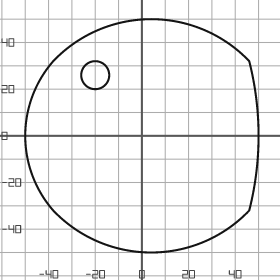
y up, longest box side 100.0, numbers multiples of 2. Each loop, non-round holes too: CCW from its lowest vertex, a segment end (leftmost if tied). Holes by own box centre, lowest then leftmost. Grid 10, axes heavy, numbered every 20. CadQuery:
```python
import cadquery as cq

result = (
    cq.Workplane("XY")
    .moveTo(-38.0, -32.0)
    .threePointArc((4.0, -50.0), (46.0, -32.0))
    .threePointArc((50.0, 0.0), (46.0, 32.0))
    .threePointArc((4.0, 50.0), (-38.0, 32.0))
    .threePointArc((-50.0, 0.0), (-38.0, -32.0))
    .close()
    .moveTo(-20.0, 26.0)
    .circle(6.0)
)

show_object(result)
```